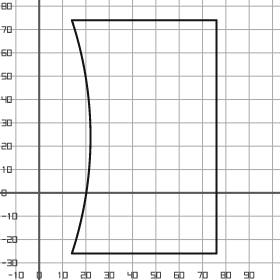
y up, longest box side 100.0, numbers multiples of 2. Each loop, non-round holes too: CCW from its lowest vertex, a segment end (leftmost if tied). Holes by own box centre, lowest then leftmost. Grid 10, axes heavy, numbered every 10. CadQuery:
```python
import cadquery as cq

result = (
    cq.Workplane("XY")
    .moveTo(14.0, -26.0)
    .lineTo(76.0, -26.0)
    .lineTo(76.0, 74.0)
    .lineTo(14.0, 74.0)
    .threePointArc((22.0, 24.0), (14.0, -26.0))
    .close()
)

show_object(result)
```